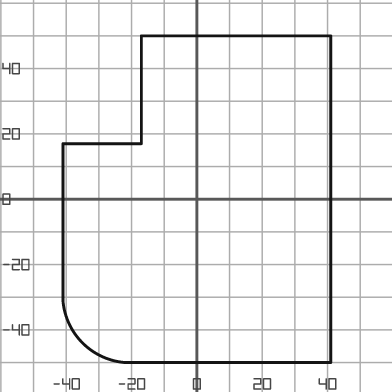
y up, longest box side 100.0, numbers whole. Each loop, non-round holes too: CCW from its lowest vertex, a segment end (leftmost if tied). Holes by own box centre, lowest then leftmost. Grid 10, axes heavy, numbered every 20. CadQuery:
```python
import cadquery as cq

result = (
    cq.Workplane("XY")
    .moveTo(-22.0, -50.0)
    .lineTo(41.0, -50.0)
    .lineTo(41.0, 50.0)
    .lineTo(-17.0, 50.0)
    .lineTo(-17.0, 17.0)
    .lineTo(-41.0, 17.0)
    .lineTo(-41.0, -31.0)
    .threePointArc((-35.0, -44.0), (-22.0, -50.0))
    .close()
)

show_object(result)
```